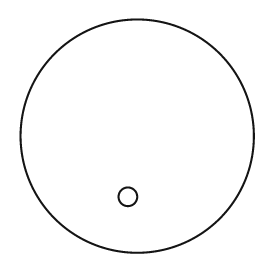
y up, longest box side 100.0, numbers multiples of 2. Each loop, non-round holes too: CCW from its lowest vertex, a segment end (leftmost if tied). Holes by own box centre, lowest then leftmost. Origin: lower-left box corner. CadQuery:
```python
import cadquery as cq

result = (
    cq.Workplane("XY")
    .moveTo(50.0, 50.0)
    .circle(50.0)
    .moveTo(46.0, 24.0)
    .circle(4.0)
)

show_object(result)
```